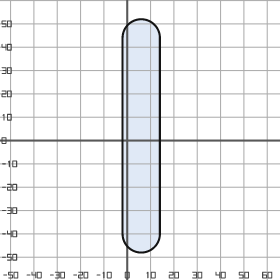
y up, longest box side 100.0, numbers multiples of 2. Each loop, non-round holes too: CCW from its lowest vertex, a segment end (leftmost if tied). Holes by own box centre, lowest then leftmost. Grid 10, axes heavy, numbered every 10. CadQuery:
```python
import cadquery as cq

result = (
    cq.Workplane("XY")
    .moveTo(-2.0, -40.0)
    .threePointArc((6.0, -48.0), (14.0, -40.0))
    .lineTo(14.0, 44.0)
    .threePointArc((6.0, 52.0), (-2.0, 44.0))
    .close()
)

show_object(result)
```